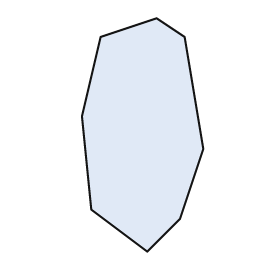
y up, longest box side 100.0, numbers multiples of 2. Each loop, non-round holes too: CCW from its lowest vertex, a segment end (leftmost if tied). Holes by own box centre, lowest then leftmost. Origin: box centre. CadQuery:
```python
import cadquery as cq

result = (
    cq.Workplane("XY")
    .moveTo(2.0, -50.0)
    .lineTo(16.0, -36.0)
    .lineTo(26.0, -6.0)
    .lineTo(18.0, 42.0)
    .lineTo(6.0, 50.0)
    .lineTo(-18.0, 42.0)
    .lineTo(-26.0, 8.0)
    .lineTo(-22.0, -32.0)
    .close()
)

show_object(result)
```